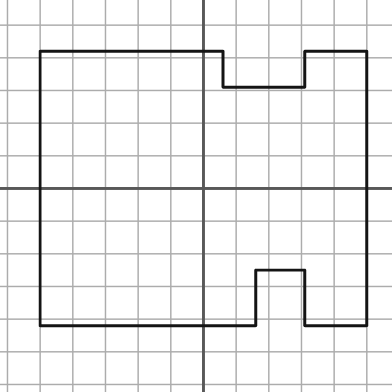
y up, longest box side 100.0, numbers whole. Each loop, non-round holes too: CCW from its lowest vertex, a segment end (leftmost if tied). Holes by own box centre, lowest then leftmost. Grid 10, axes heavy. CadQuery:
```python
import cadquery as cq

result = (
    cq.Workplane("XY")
    .moveTo(-50.0, -42.0)
    .lineTo(16.0, -42.0)
    .lineTo(16.0, -25.0)
    .lineTo(31.0, -25.0)
    .lineTo(31.0, -42.0)
    .lineTo(50.0, -42.0)
    .lineTo(50.0, 42.0)
    .lineTo(31.0, 42.0)
    .lineTo(31.0, 31.0)
    .lineTo(6.0, 31.0)
    .lineTo(6.0, 42.0)
    .lineTo(-50.0, 42.0)
    .close()
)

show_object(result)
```